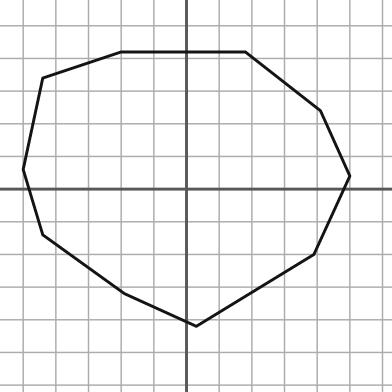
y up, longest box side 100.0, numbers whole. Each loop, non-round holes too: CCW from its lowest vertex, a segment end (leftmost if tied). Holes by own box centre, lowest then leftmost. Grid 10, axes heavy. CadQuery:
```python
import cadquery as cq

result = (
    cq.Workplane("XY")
    .moveTo(3.0, -42.0)
    .lineTo(39.0, -20.0)
    .lineTo(50.0, 4.0)
    .lineTo(41.0, 24.0)
    .lineTo(18.0, 42.0)
    .lineTo(-20.0, 42.0)
    .lineTo(-44.0, 34.0)
    .lineTo(-50.0, 6.0)
    .lineTo(-44.0, -14.0)
    .lineTo(-19.0, -32.0)
    .close()
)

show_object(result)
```